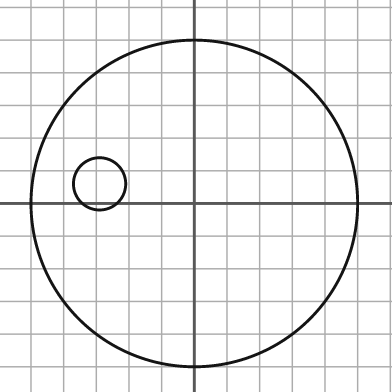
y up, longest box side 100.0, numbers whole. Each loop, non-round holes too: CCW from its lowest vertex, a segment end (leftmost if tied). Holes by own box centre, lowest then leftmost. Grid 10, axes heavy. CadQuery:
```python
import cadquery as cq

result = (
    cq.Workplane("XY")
    .moveTo(0.0, 0.0)
    .circle(50.0)
    .moveTo(-29.0, 6.0)
    .circle(8.0)
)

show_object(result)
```